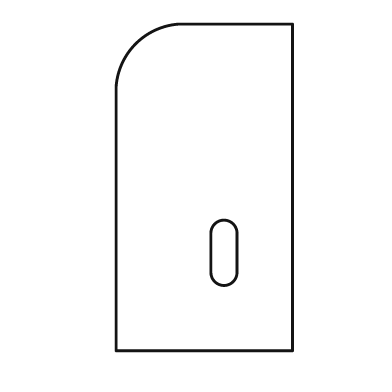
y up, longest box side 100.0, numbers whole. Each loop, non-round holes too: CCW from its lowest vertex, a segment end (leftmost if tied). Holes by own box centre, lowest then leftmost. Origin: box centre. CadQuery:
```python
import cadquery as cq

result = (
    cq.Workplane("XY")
    .moveTo(-27.0, -50.0)
    .lineTo(27.0, -50.0)
    .lineTo(27.0, 50.0)
    .lineTo(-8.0, 50.0)
    .threePointArc((-21.0, 44.0), (-27.0, 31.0))
    .close()
    .moveTo(2.0, -26.0)
    .threePointArc((6.0, -30.0), (10.0, -26.0))
    .lineTo(10.0, -14.0)
    .threePointArc((6.0, -10.0), (2.0, -14.0))
    .close()
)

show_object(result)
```